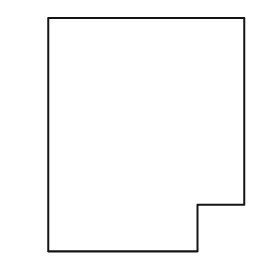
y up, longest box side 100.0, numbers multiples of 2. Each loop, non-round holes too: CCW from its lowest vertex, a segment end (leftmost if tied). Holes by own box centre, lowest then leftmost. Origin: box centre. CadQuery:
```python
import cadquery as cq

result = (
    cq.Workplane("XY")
    .moveTo(-42.0, -50.0)
    .lineTo(22.0, -50.0)
    .lineTo(22.0, -30.0)
    .lineTo(42.0, -30.0)
    .lineTo(42.0, 50.0)
    .lineTo(-42.0, 50.0)
    .close()
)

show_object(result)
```